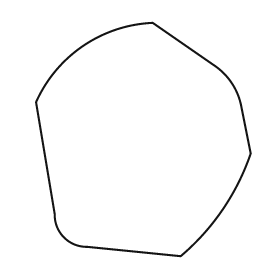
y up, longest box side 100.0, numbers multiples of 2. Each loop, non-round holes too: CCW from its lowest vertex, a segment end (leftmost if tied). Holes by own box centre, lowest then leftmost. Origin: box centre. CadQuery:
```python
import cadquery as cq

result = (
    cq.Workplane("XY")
    .moveTo(16.0, -50.0)
    .threePointArc((34.0, -30.0), (46.0, -6.0))
    .lineTo(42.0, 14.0)
    .threePointArc((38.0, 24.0), (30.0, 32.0))
    .lineTo(4.0, 50.0)
    .threePointArc((-26.0, 40.0), (-46.0, 16.0))
    .lineTo(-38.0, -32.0)
    .threePointArc((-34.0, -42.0), (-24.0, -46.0))
    .close()
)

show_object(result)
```